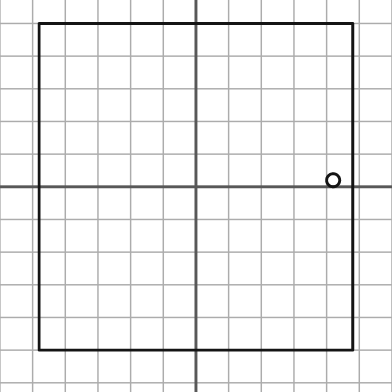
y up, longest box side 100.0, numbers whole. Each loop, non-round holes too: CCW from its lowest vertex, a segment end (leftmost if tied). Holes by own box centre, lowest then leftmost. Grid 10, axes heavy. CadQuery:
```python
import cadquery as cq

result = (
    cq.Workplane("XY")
    .moveTo(-48.0, -50.0)
    .lineTo(48.0, -50.0)
    .lineTo(48.0, 50.0)
    .lineTo(-48.0, 50.0)
    .close()
    .moveTo(42.0, 2.0)
    .circle(2.0)
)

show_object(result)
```